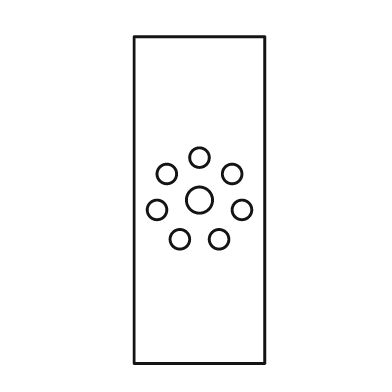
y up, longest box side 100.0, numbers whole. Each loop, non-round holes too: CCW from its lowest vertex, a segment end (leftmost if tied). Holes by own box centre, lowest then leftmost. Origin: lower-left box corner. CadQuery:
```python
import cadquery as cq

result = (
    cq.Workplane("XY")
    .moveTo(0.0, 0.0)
    .lineTo(40.0, 0.0)
    .lineTo(40.0, 100.0)
    .lineTo(0.0, 100.0)
    .close()
    .moveTo(14.0, 38.0)
    .circle(3.0)
    .moveTo(26.0, 38.0)
    .circle(3.0)
    .moveTo(7.0, 47.0)
    .circle(3.0)
    .moveTo(33.0, 47.0)
    .circle(3.0)
    .moveTo(20.0, 50.0)
    .circle(4.0)
    .moveTo(10.0, 58.0)
    .circle(3.0)
    .moveTo(30.0, 58.0)
    .circle(3.0)
    .moveTo(20.0, 63.0)
    .circle(3.0)
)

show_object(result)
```